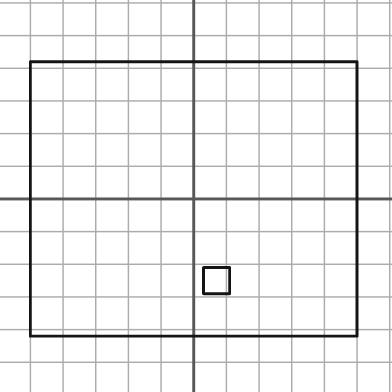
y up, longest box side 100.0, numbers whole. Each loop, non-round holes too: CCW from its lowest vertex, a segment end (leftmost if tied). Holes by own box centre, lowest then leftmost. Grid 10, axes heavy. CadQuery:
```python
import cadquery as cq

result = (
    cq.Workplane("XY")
    .moveTo(-50.0, -42.0)
    .lineTo(50.0, -42.0)
    .lineTo(50.0, 42.0)
    .lineTo(-50.0, 42.0)
    .close()
    .moveTo(3.0, -29.0)
    .lineTo(11.0, -29.0)
    .lineTo(11.0, -21.0)
    .lineTo(3.0, -21.0)
    .close()
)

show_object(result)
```